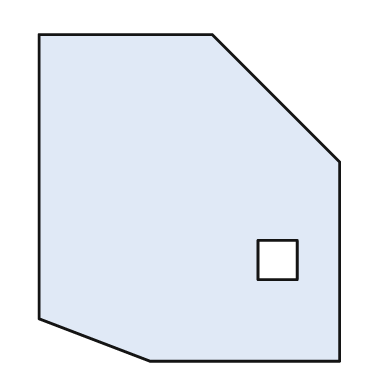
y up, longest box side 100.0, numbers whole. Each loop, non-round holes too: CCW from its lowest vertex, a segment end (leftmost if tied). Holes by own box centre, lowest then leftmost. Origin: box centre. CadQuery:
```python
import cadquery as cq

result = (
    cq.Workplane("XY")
    .moveTo(-12.0, -50.0)
    .lineTo(46.0, -50.0)
    .lineTo(46.0, 11.0)
    .lineTo(7.0, 50.0)
    .lineTo(-46.0, 50.0)
    .lineTo(-46.0, -37.0)
    .close()
    .moveTo(21.0, -25.0)
    .lineTo(33.0, -25.0)
    .lineTo(33.0, -13.0)
    .lineTo(21.0, -13.0)
    .close()
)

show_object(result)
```